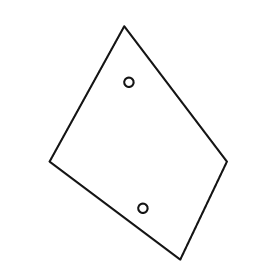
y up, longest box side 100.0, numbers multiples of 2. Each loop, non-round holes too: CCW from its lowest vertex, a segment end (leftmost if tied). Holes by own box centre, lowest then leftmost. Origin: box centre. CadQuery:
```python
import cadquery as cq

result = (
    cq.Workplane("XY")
    .moveTo(18.0, -50.0)
    .lineTo(38.0, -8.0)
    .lineTo(-6.0, 50.0)
    .lineTo(-38.0, -8.0)
    .close()
    .moveTo(2.0, -28.0)
    .circle(2.0)
    .moveTo(-4.0, 26.0)
    .circle(2.0)
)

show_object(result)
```